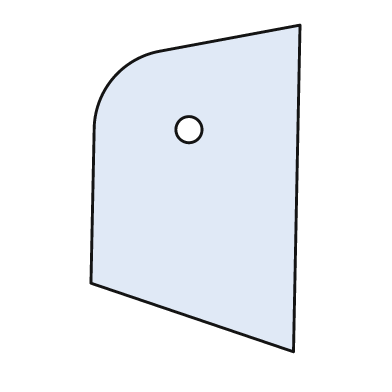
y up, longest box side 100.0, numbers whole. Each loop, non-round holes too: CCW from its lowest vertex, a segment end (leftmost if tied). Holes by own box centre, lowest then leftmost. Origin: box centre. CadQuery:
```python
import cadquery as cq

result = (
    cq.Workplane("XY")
    .moveTo(30.0, -50.0)
    .lineTo(32.0, 50.0)
    .lineTo(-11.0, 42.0)
    .threePointArc((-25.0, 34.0), (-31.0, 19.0))
    .lineTo(-32.0, -29.0)
    .close()
    .moveTo(-2.0, 18.0)
    .circle(4.0)
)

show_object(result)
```